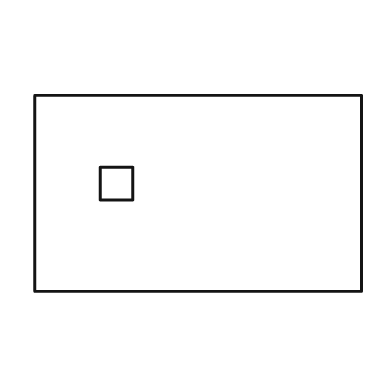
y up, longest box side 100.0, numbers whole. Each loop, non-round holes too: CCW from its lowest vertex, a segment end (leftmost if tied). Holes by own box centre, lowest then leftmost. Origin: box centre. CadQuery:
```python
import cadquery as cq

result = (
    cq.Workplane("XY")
    .moveTo(-50.0, -30.0)
    .lineTo(50.0, -30.0)
    .lineTo(50.0, 30.0)
    .lineTo(-50.0, 30.0)
    .close()
    .moveTo(-30.0, -2.0)
    .lineTo(-20.0, -2.0)
    .lineTo(-20.0, 8.0)
    .lineTo(-30.0, 8.0)
    .close()
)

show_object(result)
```